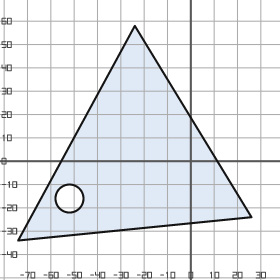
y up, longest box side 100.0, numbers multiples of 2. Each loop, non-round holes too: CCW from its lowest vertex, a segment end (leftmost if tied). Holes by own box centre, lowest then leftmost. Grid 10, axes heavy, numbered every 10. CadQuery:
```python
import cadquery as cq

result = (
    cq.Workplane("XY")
    .moveTo(-74.0, -34.0)
    .lineTo(26.0, -24.0)
    .lineTo(-24.0, 58.0)
    .close()
    .moveTo(-52.0, -16.0)
    .circle(6.0)
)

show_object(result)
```